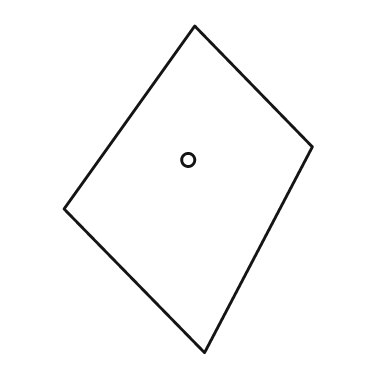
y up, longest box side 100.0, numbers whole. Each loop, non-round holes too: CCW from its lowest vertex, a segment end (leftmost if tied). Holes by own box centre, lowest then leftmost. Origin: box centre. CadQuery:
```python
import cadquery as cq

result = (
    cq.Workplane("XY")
    .moveTo(5.0, -50.0)
    .lineTo(38.0, 13.0)
    .lineTo(2.0, 50.0)
    .lineTo(-38.0, -6.0)
    .close()
    .moveTo(0.0, 9.0)
    .circle(2.0)
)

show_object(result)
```